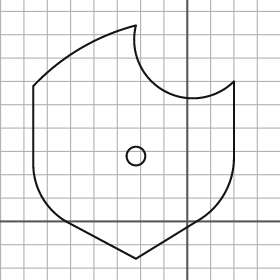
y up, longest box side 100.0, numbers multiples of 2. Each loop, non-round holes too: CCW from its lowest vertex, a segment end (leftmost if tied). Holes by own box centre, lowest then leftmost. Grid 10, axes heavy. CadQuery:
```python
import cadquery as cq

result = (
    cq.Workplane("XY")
    .moveTo(-22.0, -16.0)
    .lineTo(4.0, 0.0)
    .threePointArc((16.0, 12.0), (20.0, 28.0))
    .lineTo(20.0, 60.0)
    .threePointArc((-10.0, 56.0), (-22.0, 84.0))
    .threePointArc((-46.0, 74.0), (-66.0, 58.0))
    .lineTo(-66.0, 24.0)
    .threePointArc((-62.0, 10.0), (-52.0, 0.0))
    .close()
    .moveTo(-22.0, 28.0)
    .circle(4.0)
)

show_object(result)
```